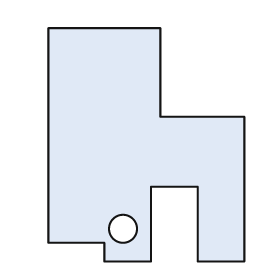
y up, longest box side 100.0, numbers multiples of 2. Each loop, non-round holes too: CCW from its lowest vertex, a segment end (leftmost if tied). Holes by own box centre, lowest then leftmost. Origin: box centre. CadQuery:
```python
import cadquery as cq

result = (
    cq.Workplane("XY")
    .moveTo(-18.0, -50.0)
    .lineTo(2.0, -50.0)
    .lineTo(2.0, -18.0)
    .lineTo(22.0, -18.0)
    .lineTo(22.0, -50.0)
    .lineTo(42.0, -50.0)
    .lineTo(42.0, 12.0)
    .lineTo(6.0, 12.0)
    .lineTo(6.0, 50.0)
    .lineTo(-42.0, 50.0)
    .lineTo(-42.0, -42.0)
    .lineTo(-18.0, -42.0)
    .close()
    .moveTo(-10.0, -36.0)
    .circle(6.0)
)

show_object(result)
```